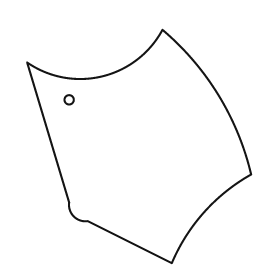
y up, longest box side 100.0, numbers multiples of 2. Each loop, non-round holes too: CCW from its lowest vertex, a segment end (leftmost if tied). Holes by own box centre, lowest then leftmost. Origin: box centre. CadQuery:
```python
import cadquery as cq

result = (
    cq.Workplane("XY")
    .moveTo(14.0, -50.0)
    .threePointArc((28.0, -28.0), (48.0, -12.0))
    .threePointArc((34.0, 22.0), (10.0, 50.0))
    .threePointArc((-16.0, 30.0), (-48.0, 36.0))
    .lineTo(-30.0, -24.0)
    .threePointArc((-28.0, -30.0), (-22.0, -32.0))
    .close()
    .moveTo(-30.0, 20.0)
    .circle(2.0)
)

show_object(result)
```